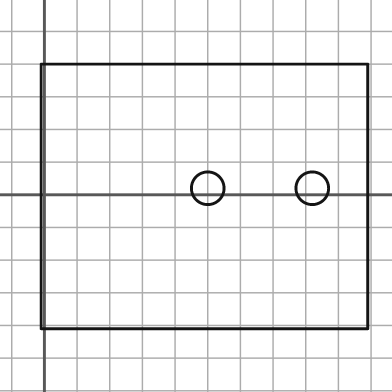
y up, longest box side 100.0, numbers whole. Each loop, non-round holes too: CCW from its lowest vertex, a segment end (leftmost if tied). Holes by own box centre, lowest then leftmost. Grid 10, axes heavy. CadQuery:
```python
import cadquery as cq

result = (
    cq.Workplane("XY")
    .moveTo(-1.0, -41.0)
    .lineTo(99.0, -41.0)
    .lineTo(99.0, 40.0)
    .lineTo(-1.0, 40.0)
    .close()
    .moveTo(50.0, 2.0)
    .circle(5.0)
    .moveTo(82.0, 2.0)
    .circle(5.0)
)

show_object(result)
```